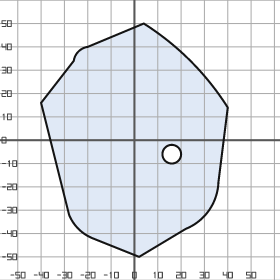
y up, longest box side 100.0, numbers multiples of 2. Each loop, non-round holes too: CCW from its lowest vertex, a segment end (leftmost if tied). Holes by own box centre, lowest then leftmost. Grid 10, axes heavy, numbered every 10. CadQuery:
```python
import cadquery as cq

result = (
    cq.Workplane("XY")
    .moveTo(2.0, -50.0)
    .lineTo(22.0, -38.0)
    .threePointArc((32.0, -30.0), (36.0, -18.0))
    .lineTo(40.0, 14.0)
    .threePointArc((24.0, 34.0), (4.0, 50.0))
    .lineTo(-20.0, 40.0)
    .threePointArc((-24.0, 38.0), (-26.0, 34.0))
    .lineTo(-40.0, 16.0)
    .lineTo(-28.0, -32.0)
    .threePointArc((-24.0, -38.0), (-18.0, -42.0))
    .close()
    .moveTo(16.0, -6.0)
    .circle(4.0)
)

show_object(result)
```